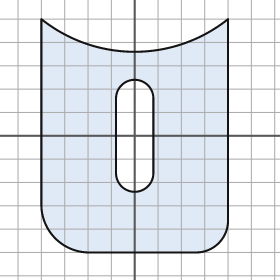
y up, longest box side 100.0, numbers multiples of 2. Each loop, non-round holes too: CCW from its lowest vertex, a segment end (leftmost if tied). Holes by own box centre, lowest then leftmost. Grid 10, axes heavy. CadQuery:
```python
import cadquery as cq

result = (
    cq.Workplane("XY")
    .moveTo(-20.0, -50.0)
    .lineTo(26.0, -50.0)
    .threePointArc((36.0, -46.0), (40.0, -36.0))
    .lineTo(40.0, 50.0)
    .threePointArc((0.0, 36.0), (-40.0, 50.0))
    .lineTo(-40.0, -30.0)
    .threePointArc((-34.0, -44.0), (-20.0, -50.0))
    .close()
    .moveTo(-8.0, -16.0)
    .threePointArc((0.0, -24.0), (8.0, -16.0))
    .lineTo(8.0, 16.0)
    .threePointArc((0.0, 24.0), (-8.0, 16.0))
    .close()
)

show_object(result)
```